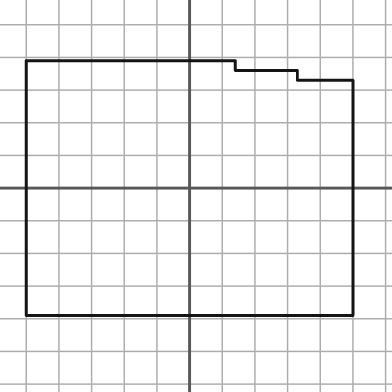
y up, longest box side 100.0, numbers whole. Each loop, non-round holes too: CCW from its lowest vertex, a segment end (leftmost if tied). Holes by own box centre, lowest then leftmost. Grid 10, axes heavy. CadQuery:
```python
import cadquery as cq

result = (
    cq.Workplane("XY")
    .moveTo(-50.0, -39.0)
    .lineTo(50.0, -39.0)
    .lineTo(50.0, 33.0)
    .lineTo(33.0, 33.0)
    .lineTo(33.0, 36.0)
    .lineTo(14.0, 36.0)
    .lineTo(14.0, 39.0)
    .lineTo(-50.0, 39.0)
    .close()
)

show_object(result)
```